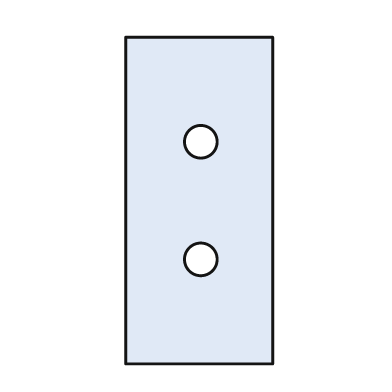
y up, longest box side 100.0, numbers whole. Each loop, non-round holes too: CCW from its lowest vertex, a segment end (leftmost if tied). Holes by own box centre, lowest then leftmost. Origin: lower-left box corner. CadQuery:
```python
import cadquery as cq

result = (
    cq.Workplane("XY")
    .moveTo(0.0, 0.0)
    .lineTo(45.0, 0.0)
    .lineTo(45.0, 100.0)
    .lineTo(0.0, 100.0)
    .close()
    .moveTo(23.0, 32.0)
    .circle(5.0)
    .moveTo(23.0, 68.0)
    .circle(5.0)
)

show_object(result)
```